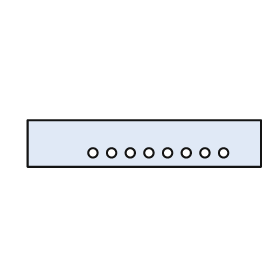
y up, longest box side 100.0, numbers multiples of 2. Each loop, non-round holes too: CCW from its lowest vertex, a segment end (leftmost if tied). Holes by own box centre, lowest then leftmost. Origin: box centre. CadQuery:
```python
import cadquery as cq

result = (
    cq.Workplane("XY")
    .moveTo(-50.0, -10.0)
    .lineTo(50.0, -10.0)
    .lineTo(50.0, 10.0)
    .lineTo(-50.0, 10.0)
    .close()
    .moveTo(-22.0, -4.0)
    .circle(2.0)
    .moveTo(-14.0, -4.0)
    .circle(2.0)
    .moveTo(-6.0, -4.0)
    .circle(2.0)
    .moveTo(2.0, -4.0)
    .circle(2.0)
    .moveTo(10.0, -4.0)
    .circle(2.0)
    .moveTo(18.0, -4.0)
    .circle(2.0)
    .moveTo(26.0, -4.0)
    .circle(2.0)
    .moveTo(34.0, -4.0)
    .circle(2.0)
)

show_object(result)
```